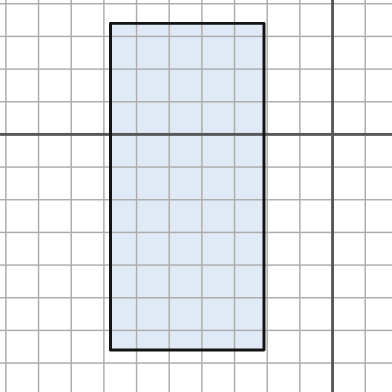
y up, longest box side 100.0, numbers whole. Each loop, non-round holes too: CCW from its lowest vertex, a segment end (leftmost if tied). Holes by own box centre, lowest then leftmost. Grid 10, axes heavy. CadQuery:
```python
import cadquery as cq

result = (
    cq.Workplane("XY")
    .moveTo(-68.0, -66.0)
    .lineTo(-21.0, -66.0)
    .lineTo(-21.0, 34.0)
    .lineTo(-68.0, 34.0)
    .close()
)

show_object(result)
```